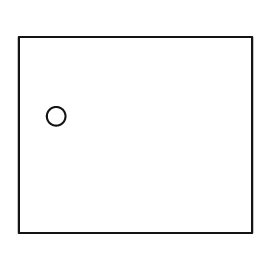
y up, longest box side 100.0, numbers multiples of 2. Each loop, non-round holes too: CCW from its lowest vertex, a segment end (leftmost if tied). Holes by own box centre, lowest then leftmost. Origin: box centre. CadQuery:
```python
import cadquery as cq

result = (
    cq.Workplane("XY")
    .moveTo(-50.0, -42.0)
    .lineTo(50.0, -42.0)
    .lineTo(50.0, 42.0)
    .lineTo(-50.0, 42.0)
    .close()
    .moveTo(-34.0, 8.0)
    .circle(4.0)
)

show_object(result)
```